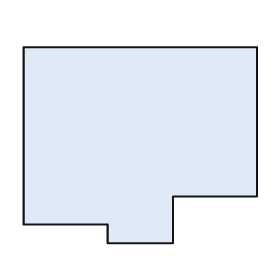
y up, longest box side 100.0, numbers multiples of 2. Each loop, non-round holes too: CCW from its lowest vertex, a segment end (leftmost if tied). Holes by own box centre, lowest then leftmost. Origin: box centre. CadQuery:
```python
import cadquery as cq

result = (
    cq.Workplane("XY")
    .moveTo(-14.0, -42.0)
    .lineTo(14.0, -42.0)
    .lineTo(14.0, -22.0)
    .lineTo(50.0, -22.0)
    .lineTo(50.0, 42.0)
    .lineTo(-50.0, 42.0)
    .lineTo(-50.0, -34.0)
    .lineTo(-14.0, -34.0)
    .close()
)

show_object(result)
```